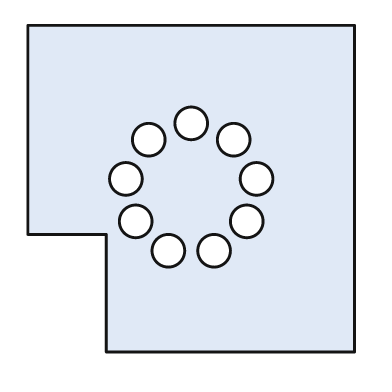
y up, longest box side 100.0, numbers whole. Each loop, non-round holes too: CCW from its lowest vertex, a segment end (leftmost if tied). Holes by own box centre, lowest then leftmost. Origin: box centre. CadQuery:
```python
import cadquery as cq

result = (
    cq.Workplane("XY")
    .moveTo(-26.0, -50.0)
    .lineTo(50.0, -50.0)
    .lineTo(50.0, 50.0)
    .lineTo(-50.0, 50.0)
    .lineTo(-50.0, -14.0)
    .lineTo(-26.0, -14.0)
    .close()
    .moveTo(-7.0, -19.0)
    .circle(5.0)
    .moveTo(7.0, -19.0)
    .circle(5.0)
    .moveTo(-17.0, -10.0)
    .circle(5.0)
    .moveTo(17.0, -10.0)
    .circle(5.0)
    .moveTo(-20.0, 3.0)
    .circle(5.0)
    .moveTo(20.0, 3.0)
    .circle(5.0)
    .moveTo(-13.0, 15.0)
    .circle(5.0)
    .moveTo(13.0, 15.0)
    .circle(5.0)
    .moveTo(0.0, 20.0)
    .circle(5.0)
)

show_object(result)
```